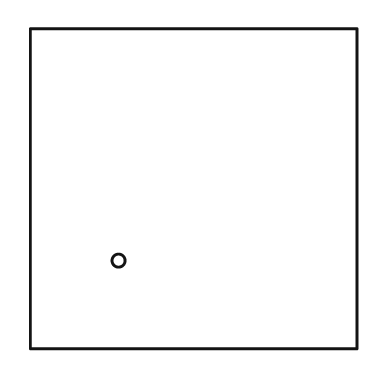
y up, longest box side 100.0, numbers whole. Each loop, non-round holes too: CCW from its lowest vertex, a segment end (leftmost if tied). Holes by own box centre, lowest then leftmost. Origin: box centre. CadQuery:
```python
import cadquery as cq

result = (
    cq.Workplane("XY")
    .moveTo(-50.0, -49.0)
    .lineTo(50.0, -49.0)
    .lineTo(50.0, 49.0)
    .lineTo(-50.0, 49.0)
    .close()
    .moveTo(-23.0, -22.0)
    .circle(2.0)
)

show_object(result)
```